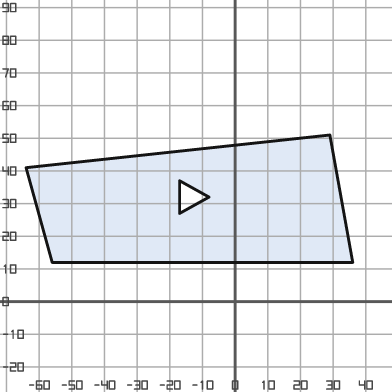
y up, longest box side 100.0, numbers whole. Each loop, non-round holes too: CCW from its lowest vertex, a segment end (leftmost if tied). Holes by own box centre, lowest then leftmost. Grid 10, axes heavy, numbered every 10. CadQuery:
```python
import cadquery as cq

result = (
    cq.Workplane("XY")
    .moveTo(-56.0, 12.0)
    .lineTo(36.0, 12.0)
    .lineTo(29.0, 51.0)
    .lineTo(-64.0, 41.0)
    .close()
    .moveTo(-17.0, 27.0)
    .lineTo(-8.0, 32.0)
    .lineTo(-17.0, 37.0)
    .close()
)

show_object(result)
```